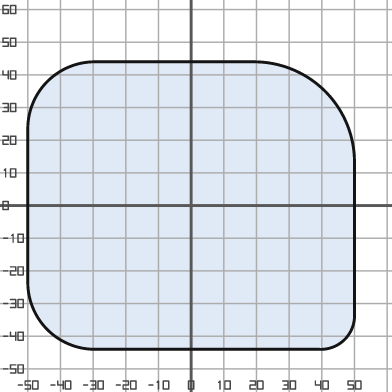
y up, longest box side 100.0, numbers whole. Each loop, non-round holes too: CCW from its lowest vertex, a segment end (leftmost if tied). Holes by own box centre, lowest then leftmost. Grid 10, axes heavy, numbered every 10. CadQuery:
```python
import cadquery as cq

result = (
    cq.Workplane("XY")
    .moveTo(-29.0, -44.0)
    .lineTo(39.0, -44.0)
    .threePointArc((47.0, -41.0), (50.0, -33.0))
    .lineTo(50.0, 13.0)
    .threePointArc((41.0, 35.0), (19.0, 44.0))
    .lineTo(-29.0, 44.0)
    .threePointArc((-44.0, 38.0), (-50.0, 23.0))
    .lineTo(-50.0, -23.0)
    .threePointArc((-44.0, -38.0), (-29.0, -44.0))
    .close()
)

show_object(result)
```